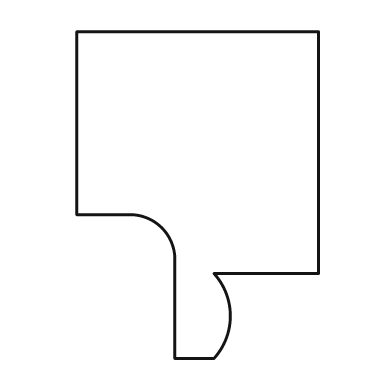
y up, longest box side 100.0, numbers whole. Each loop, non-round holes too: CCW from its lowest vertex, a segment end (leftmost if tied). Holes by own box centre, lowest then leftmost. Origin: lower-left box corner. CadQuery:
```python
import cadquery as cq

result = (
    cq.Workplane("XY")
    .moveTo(30.0, 0.0)
    .lineTo(42.0, 0.0)
    .threePointArc((47.0, 13.0), (42.0, 26.0))
    .lineTo(74.0, 26.0)
    .lineTo(74.0, 100.0)
    .lineTo(0.0, 100.0)
    .lineTo(0.0, 44.0)
    .lineTo(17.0, 44.0)
    .threePointArc((26.0, 40.0), (30.0, 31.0))
    .close()
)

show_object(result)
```